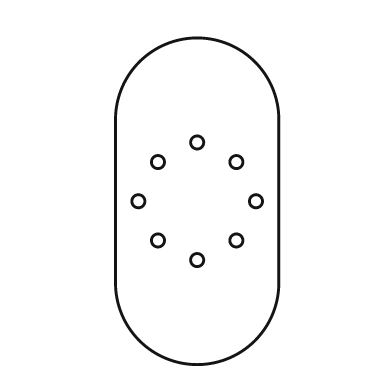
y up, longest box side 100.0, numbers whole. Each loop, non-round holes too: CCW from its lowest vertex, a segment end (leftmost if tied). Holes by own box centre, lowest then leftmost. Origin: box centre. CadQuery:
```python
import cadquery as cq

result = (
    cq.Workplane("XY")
    .moveTo(-25.0, -25.0)
    .threePointArc((0.0, -50.0), (25.0, -25.0))
    .lineTo(25.0, 25.0)
    .threePointArc((0.0, 50.0), (-25.0, 25.0))
    .close()
    .moveTo(0.0, -18.0)
    .circle(2.0)
    .moveTo(-12.0, -12.0)
    .circle(2.0)
    .moveTo(12.0, -12.0)
    .circle(2.0)
    .moveTo(-18.0, 0.0)
    .circle(2.0)
    .moveTo(18.0, 0.0)
    .circle(2.0)
    .moveTo(-12.0, 12.0)
    .circle(2.0)
    .moveTo(12.0, 12.0)
    .circle(2.0)
    .moveTo(0.0, 18.0)
    .circle(2.0)
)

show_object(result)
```